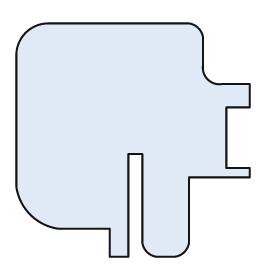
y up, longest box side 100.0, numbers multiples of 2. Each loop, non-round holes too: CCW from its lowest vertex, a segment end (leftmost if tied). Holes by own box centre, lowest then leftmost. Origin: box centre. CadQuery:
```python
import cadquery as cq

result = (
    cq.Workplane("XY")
    .moveTo(-10.0, -50.0)
    .lineTo(-2.0, -50.0)
    .lineTo(-2.0, -6.0)
    .lineTo(4.0, -6.0)
    .lineTo(4.0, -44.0)
    .threePointArc((6.0, -48.0), (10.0, -50.0))
    .lineTo(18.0, -50.0)
    .threePointArc((22.0, -48.0), (24.0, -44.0))
    .lineTo(24.0, -16.0)
    .lineTo(50.0, -16.0)
    .lineTo(50.0, -12.0)
    .lineTo(40.0, -12.0)
    .lineTo(40.0, 14.0)
    .lineTo(50.0, 14.0)
    .lineTo(50.0, 24.0)
    .lineTo(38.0, 24.0)
    .threePointArc((32.0, 26.0), (30.0, 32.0))
    .lineTo(30.0, 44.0)
    .threePointArc((28.0, 48.0), (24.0, 50.0))
    .lineTo(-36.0, 50.0)
    .threePointArc((-46.0, 46.0), (-50.0, 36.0))
    .lineTo(-50.0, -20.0)
    .threePointArc((-44.0, -32.0), (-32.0, -38.0))
    .lineTo(-10.0, -38.0)
    .close()
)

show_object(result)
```